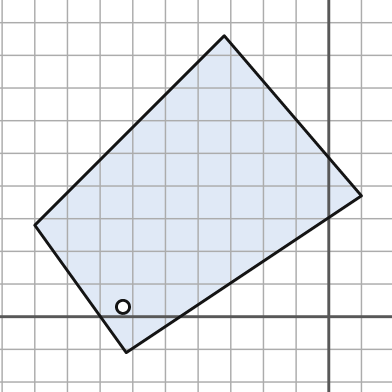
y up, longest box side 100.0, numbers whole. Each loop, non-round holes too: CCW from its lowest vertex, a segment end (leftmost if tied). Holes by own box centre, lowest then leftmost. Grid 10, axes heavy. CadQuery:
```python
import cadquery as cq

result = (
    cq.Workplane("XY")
    .moveTo(-62.0, -11.0)
    .lineTo(10.0, 37.0)
    .lineTo(-32.0, 86.0)
    .lineTo(-90.0, 28.0)
    .close()
    .moveTo(-63.0, 3.0)
    .circle(2.0)
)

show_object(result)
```